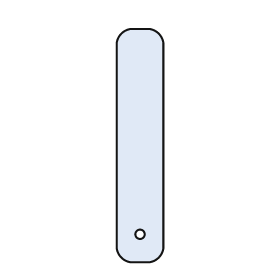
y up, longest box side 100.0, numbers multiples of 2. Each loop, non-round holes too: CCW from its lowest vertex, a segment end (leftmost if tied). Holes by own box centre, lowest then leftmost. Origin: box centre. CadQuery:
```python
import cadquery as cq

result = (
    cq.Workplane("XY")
    .moveTo(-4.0, -50.0)
    .lineTo(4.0, -50.0)
    .threePointArc((8.0, -48.0), (10.0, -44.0))
    .lineTo(10.0, 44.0)
    .threePointArc((8.0, 48.0), (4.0, 50.0))
    .lineTo(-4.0, 50.0)
    .threePointArc((-8.0, 48.0), (-10.0, 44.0))
    .lineTo(-10.0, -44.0)
    .threePointArc((-8.0, -48.0), (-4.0, -50.0))
    .close()
    .moveTo(0.0, -38.0)
    .circle(2.0)
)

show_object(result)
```